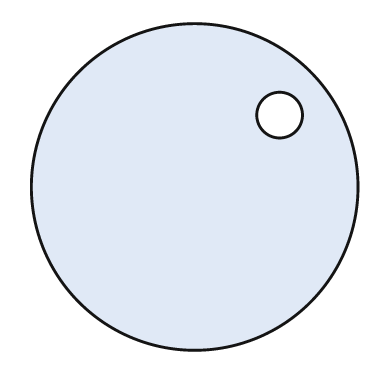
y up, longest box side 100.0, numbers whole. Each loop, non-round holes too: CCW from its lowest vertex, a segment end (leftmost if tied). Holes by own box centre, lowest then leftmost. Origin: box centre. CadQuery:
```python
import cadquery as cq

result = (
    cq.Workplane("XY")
    .moveTo(0.0, 0.0)
    .circle(50.0)
    .moveTo(26.0, 22.0)
    .circle(7.0)
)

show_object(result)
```